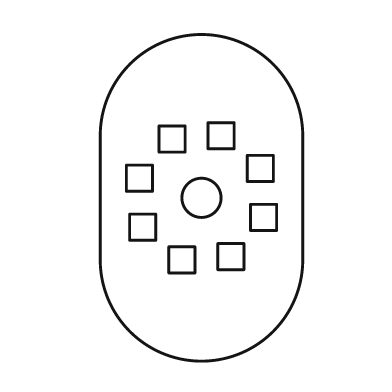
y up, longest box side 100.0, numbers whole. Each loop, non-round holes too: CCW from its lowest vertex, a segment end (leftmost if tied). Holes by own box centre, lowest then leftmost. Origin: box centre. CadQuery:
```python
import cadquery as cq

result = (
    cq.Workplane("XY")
    .moveTo(-31.0, -19.0)
    .threePointArc((0.0, -50.0), (31.0, -19.0))
    .lineTo(31.0, 19.0)
    .threePointArc((0.0, 50.0), (-31.0, 19.0))
    .close()
    .moveTo(-10.0, -23.0)
    .lineTo(-2.0, -23.0)
    .lineTo(-2.0, -15.0)
    .lineTo(-10.0, -15.0)
    .close()
    .moveTo(5.0, -22.0)
    .lineTo(13.0, -22.0)
    .lineTo(13.0, -14.0)
    .lineTo(5.0, -14.0)
    .close()
    .moveTo(-22.0, -13.0)
    .lineTo(-14.0, -13.0)
    .lineTo(-14.0, -5.0)
    .lineTo(-22.0, -5.0)
    .close()
    .moveTo(15.0, -10.0)
    .lineTo(23.0, -10.0)
    .lineTo(23.0, -2.0)
    .lineTo(15.0, -2.0)
    .close()
    .moveTo(0.0, 0.0)
    .circle(6.0)
    .moveTo(-23.0, 2.0)
    .lineTo(-15.0, 2.0)
    .lineTo(-15.0, 10.0)
    .lineTo(-23.0, 10.0)
    .close()
    .moveTo(14.0, 5.0)
    .lineTo(22.0, 5.0)
    .lineTo(22.0, 13.0)
    .lineTo(14.0, 13.0)
    .close()
    .moveTo(-13.0, 14.0)
    .lineTo(-5.0, 14.0)
    .lineTo(-5.0, 22.0)
    .lineTo(-13.0, 22.0)
    .close()
    .moveTo(2.0, 15.0)
    .lineTo(10.0, 15.0)
    .lineTo(10.0, 23.0)
    .lineTo(2.0, 23.0)
    .close()
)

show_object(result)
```